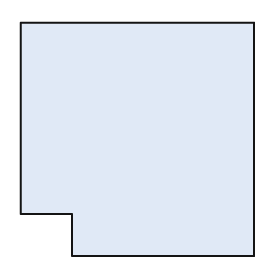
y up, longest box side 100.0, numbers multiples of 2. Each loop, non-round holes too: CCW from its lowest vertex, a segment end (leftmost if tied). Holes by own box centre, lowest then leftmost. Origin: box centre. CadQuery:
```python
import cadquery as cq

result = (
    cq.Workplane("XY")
    .moveTo(-28.0, -50.0)
    .lineTo(50.0, -50.0)
    .lineTo(50.0, 50.0)
    .lineTo(-50.0, 50.0)
    .lineTo(-50.0, -32.0)
    .lineTo(-28.0, -32.0)
    .close()
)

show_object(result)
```